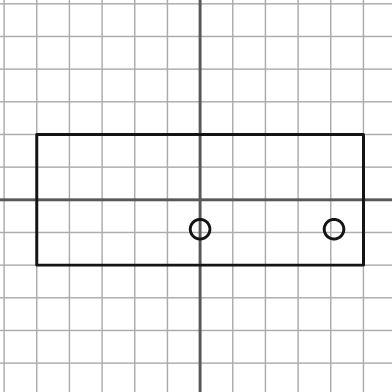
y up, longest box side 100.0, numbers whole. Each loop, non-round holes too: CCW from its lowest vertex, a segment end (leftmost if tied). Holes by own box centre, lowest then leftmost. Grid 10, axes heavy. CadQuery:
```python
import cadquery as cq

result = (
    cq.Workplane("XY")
    .moveTo(-50.0, -20.0)
    .lineTo(50.0, -20.0)
    .lineTo(50.0, 20.0)
    .lineTo(-50.0, 20.0)
    .close()
    .moveTo(0.0, -9.0)
    .circle(3.0)
    .moveTo(41.0, -9.0)
    .circle(3.0)
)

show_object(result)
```